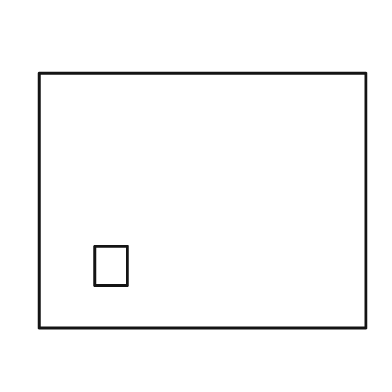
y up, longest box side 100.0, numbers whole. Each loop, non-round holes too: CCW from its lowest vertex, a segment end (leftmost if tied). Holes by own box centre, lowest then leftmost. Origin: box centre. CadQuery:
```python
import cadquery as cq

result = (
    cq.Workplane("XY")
    .moveTo(-50.0, -39.0)
    .lineTo(50.0, -39.0)
    .lineTo(50.0, 39.0)
    .lineTo(-50.0, 39.0)
    .close()
    .moveTo(-33.0, -26.0)
    .lineTo(-23.0, -26.0)
    .lineTo(-23.0, -14.0)
    .lineTo(-33.0, -14.0)
    .close()
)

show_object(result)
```